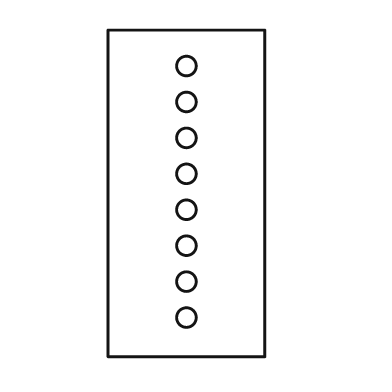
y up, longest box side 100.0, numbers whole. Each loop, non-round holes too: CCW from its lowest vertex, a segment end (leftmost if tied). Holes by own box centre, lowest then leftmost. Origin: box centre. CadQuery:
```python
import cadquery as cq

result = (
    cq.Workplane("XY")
    .moveTo(-24.0, -50.0)
    .lineTo(24.0, -50.0)
    .lineTo(24.0, 50.0)
    .lineTo(-24.0, 50.0)
    .close()
    .moveTo(0.0, -38.0)
    .circle(3.0)
    .moveTo(0.0, -27.0)
    .circle(3.0)
    .moveTo(0.0, -16.0)
    .circle(3.0)
    .moveTo(0.0, -5.0)
    .circle(3.0)
    .moveTo(0.0, 6.0)
    .circle(3.0)
    .moveTo(0.0, 17.0)
    .circle(3.0)
    .moveTo(0.0, 28.0)
    .circle(3.0)
    .moveTo(0.0, 39.0)
    .circle(3.0)
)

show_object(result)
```